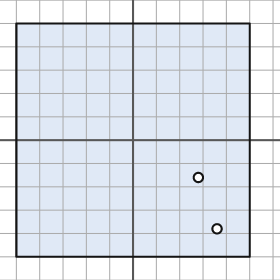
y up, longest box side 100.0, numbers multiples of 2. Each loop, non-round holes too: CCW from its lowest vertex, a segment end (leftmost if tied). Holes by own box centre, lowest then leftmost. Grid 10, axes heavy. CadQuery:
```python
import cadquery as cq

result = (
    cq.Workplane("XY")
    .moveTo(-50.0, -50.0)
    .lineTo(50.0, -50.0)
    .lineTo(50.0, 50.0)
    .lineTo(-50.0, 50.0)
    .close()
    .moveTo(36.0, -38.0)
    .circle(2.0)
    .moveTo(28.0, -16.0)
    .circle(2.0)
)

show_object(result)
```